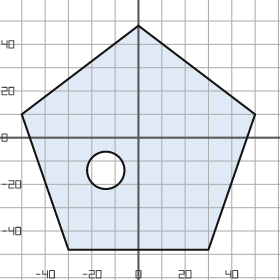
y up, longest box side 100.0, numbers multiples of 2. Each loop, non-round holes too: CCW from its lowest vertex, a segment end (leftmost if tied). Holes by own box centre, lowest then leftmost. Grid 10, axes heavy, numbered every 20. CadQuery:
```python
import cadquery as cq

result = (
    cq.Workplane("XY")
    .moveTo(-30.0, -48.0)
    .lineTo(30.0, -48.0)
    .lineTo(50.0, 10.0)
    .lineTo(0.0, 48.0)
    .lineTo(-50.0, 10.0)
    .close()
    .moveTo(-14.0, -14.0)
    .circle(8.0)
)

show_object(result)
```